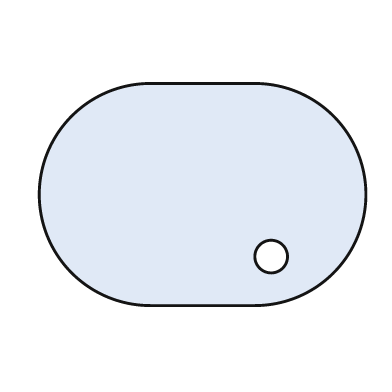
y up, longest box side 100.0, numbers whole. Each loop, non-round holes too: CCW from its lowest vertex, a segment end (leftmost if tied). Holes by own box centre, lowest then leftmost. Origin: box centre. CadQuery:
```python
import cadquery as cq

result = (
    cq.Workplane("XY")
    .moveTo(-16.0, -34.0)
    .lineTo(16.0, -34.0)
    .threePointArc((50.0, 0.0), (16.0, 34.0))
    .lineTo(-16.0, 34.0)
    .threePointArc((-50.0, 0.0), (-16.0, -34.0))
    .close()
    .moveTo(21.0, -19.0)
    .circle(5.0)
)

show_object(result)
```